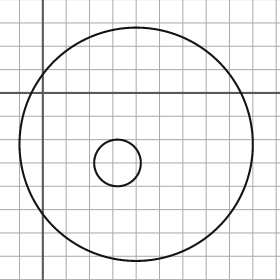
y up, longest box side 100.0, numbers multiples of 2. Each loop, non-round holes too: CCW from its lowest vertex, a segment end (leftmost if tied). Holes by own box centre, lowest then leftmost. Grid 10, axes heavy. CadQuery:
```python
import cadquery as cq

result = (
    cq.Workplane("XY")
    .moveTo(40.0, -22.0)
    .circle(50.0)
    .moveTo(32.0, -30.0)
    .circle(10.0)
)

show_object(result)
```